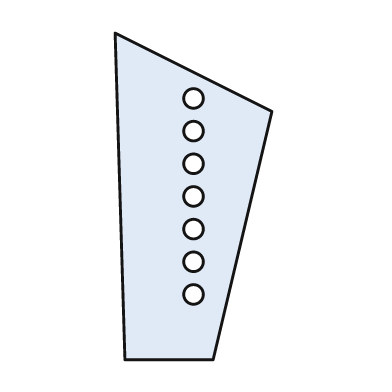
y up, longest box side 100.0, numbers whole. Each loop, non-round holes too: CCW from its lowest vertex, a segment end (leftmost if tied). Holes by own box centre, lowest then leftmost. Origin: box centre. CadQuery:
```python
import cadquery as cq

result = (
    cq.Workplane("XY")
    .moveTo(-21.0, -50.0)
    .lineTo(6.0, -50.0)
    .lineTo(24.0, 26.0)
    .lineTo(-24.0, 50.0)
    .close()
    .moveTo(0.0, -30.0)
    .circle(3.0)
    .moveTo(0.0, -20.0)
    .circle(3.0)
    .moveTo(0.0, -10.0)
    .circle(3.0)
    .moveTo(0.0, 0.0)
    .circle(3.0)
    .moveTo(0.0, 10.0)
    .circle(3.0)
    .moveTo(0.0, 20.0)
    .circle(3.0)
    .moveTo(0.0, 30.0)
    .circle(3.0)
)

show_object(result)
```